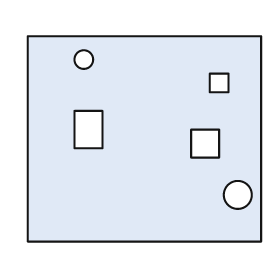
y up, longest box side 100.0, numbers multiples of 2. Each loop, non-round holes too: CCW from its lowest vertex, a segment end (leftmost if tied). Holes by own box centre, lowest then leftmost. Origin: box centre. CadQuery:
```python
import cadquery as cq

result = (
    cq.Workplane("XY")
    .moveTo(-50.0, -44.0)
    .lineTo(50.0, -44.0)
    .lineTo(50.0, 44.0)
    .lineTo(-50.0, 44.0)
    .close()
    .moveTo(40.0, -24.0)
    .circle(6.0)
    .moveTo(20.0, -8.0)
    .lineTo(32.0, -8.0)
    .lineTo(32.0, 4.0)
    .lineTo(20.0, 4.0)
    .close()
    .moveTo(-30.0, -4.0)
    .lineTo(-18.0, -4.0)
    .lineTo(-18.0, 12.0)
    .lineTo(-30.0, 12.0)
    .close()
    .moveTo(28.0, 20.0)
    .lineTo(36.0, 20.0)
    .lineTo(36.0, 28.0)
    .lineTo(28.0, 28.0)
    .close()
    .moveTo(-26.0, 34.0)
    .circle(4.0)
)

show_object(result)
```